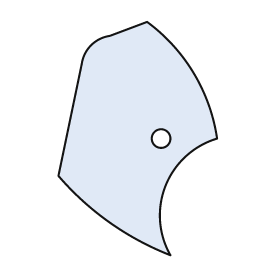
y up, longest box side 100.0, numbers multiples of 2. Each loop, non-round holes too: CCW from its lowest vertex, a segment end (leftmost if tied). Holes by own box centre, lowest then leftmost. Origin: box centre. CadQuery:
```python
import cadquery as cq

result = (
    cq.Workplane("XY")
    .moveTo(14.0, -50.0)
    .threePointArc((12.0, -20.0), (34.0, 0.0))
    .threePointArc((24.0, 28.0), (4.0, 50.0))
    .lineTo(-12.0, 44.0)
    .threePointArc((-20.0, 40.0), (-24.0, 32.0))
    .lineTo(-34.0, -16.0)
    .threePointArc((-12.0, -36.0), (14.0, -50.0))
    .close()
    .moveTo(10.0, 0.0)
    .circle(4.0)
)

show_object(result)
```